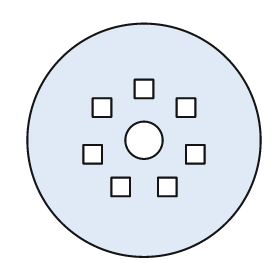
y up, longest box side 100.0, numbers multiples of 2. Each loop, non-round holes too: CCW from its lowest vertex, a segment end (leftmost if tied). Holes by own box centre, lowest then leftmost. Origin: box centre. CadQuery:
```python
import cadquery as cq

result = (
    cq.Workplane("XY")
    .moveTo(0.0, 0.0)
    .circle(50.0)
    .moveTo(-14.0, -24.0)
    .lineTo(-6.0, -24.0)
    .lineTo(-6.0, -16.0)
    .lineTo(-14.0, -16.0)
    .close()
    .moveTo(6.0, -24.0)
    .lineTo(14.0, -24.0)
    .lineTo(14.0, -16.0)
    .lineTo(6.0, -16.0)
    .close()
    .moveTo(-26.0, -10.0)
    .lineTo(-18.0, -10.0)
    .lineTo(-18.0, -2.0)
    .lineTo(-26.0, -2.0)
    .close()
    .moveTo(18.0, -10.0)
    .lineTo(26.0, -10.0)
    .lineTo(26.0, -2.0)
    .lineTo(18.0, -2.0)
    .close()
    .moveTo(0.0, 0.0)
    .circle(8.0)
    .moveTo(-22.0, 10.0)
    .lineTo(-14.0, 10.0)
    .lineTo(-14.0, 18.0)
    .lineTo(-22.0, 18.0)
    .close()
    .moveTo(14.0, 10.0)
    .lineTo(22.0, 10.0)
    .lineTo(22.0, 18.0)
    .lineTo(14.0, 18.0)
    .close()
    .moveTo(-4.0, 18.0)
    .lineTo(4.0, 18.0)
    .lineTo(4.0, 26.0)
    .lineTo(-4.0, 26.0)
    .close()
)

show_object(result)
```